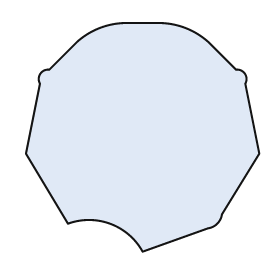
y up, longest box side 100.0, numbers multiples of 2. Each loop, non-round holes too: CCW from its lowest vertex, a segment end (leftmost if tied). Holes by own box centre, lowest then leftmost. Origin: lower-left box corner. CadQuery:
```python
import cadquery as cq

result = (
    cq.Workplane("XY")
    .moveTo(50.0, 0.0)
    .lineTo(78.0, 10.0)
    .threePointArc((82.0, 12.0), (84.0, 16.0))
    .lineTo(100.0, 42.0)
    .lineTo(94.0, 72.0)
    .threePointArc((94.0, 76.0), (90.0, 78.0))
    .lineTo(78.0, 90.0)
    .threePointArc((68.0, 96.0), (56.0, 98.0))
    .lineTo(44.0, 98.0)
    .threePointArc((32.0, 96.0), (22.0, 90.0))
    .lineTo(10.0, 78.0)
    .threePointArc((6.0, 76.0), (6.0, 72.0))
    .lineTo(0.0, 42.0)
    .lineTo(18.0, 12.0)
    .threePointArc((36.0, 12.0), (50.0, 0.0))
    .close()
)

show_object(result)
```